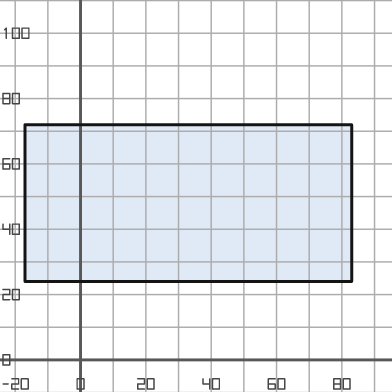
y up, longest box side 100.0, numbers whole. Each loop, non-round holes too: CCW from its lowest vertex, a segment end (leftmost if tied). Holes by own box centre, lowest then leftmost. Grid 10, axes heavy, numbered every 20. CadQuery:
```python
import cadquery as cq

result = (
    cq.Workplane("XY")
    .moveTo(-17.0, 24.0)
    .lineTo(83.0, 24.0)
    .lineTo(83.0, 72.0)
    .lineTo(-17.0, 72.0)
    .close()
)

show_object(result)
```